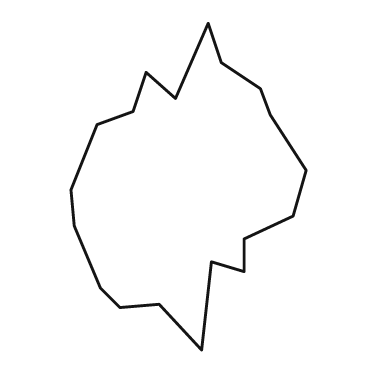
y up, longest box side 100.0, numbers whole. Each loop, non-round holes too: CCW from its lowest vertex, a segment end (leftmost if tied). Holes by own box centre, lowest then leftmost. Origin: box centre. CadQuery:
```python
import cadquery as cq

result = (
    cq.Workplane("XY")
    .moveTo(4.0, -50.0)
    .lineTo(7.0, -23.0)
    .lineTo(17.0, -26.0)
    .lineTo(17.0, -16.0)
    .lineTo(32.0, -9.0)
    .lineTo(36.0, 5.0)
    .lineTo(25.0, 22.0)
    .lineTo(22.0, 30.0)
    .lineTo(10.0, 38.0)
    .lineTo(6.0, 50.0)
    .lineTo(-4.0, 27.0)
    .lineTo(-13.0, 35.0)
    .lineTo(-17.0, 23.0)
    .lineTo(-28.0, 19.0)
    .lineTo(-36.0, -1.0)
    .lineTo(-35.0, -12.0)
    .lineTo(-27.0, -31.0)
    .lineTo(-21.0, -37.0)
    .lineTo(-9.0, -36.0)
    .close()
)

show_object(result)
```